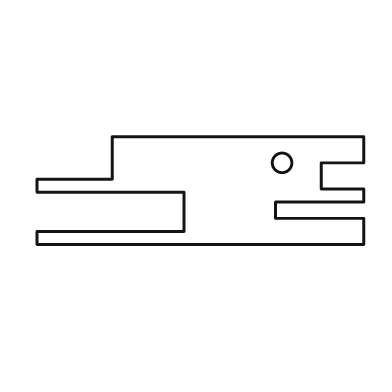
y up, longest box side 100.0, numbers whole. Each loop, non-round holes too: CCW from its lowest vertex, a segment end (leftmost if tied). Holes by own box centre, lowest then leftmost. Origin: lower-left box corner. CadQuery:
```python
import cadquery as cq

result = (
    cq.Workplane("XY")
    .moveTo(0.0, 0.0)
    .lineTo(100.0, 0.0)
    .lineTo(100.0, 8.0)
    .lineTo(73.0, 8.0)
    .lineTo(73.0, 13.0)
    .lineTo(100.0, 13.0)
    .lineTo(100.0, 17.0)
    .lineTo(87.0, 17.0)
    .lineTo(87.0, 25.0)
    .lineTo(100.0, 25.0)
    .lineTo(100.0, 33.0)
    .lineTo(23.0, 33.0)
    .lineTo(23.0, 20.0)
    .lineTo(0.0, 20.0)
    .lineTo(0.0, 16.0)
    .lineTo(45.0, 16.0)
    .lineTo(45.0, 4.0)
    .lineTo(0.0, 4.0)
    .close()
    .moveTo(75.0, 25.0)
    .circle(3.0)
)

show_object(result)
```